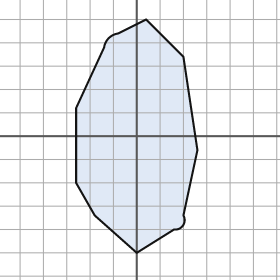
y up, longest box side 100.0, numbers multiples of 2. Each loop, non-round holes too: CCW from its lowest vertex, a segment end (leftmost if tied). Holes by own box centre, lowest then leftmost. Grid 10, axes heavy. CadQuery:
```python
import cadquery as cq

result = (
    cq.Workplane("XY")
    .moveTo(0.0, -50.0)
    .lineTo(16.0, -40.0)
    .threePointArc((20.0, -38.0), (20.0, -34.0))
    .lineTo(26.0, -6.0)
    .lineTo(20.0, 34.0)
    .lineTo(4.0, 50.0)
    .lineTo(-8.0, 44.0)
    .threePointArc((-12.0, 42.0), (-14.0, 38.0))
    .lineTo(-26.0, 12.0)
    .lineTo(-26.0, -20.0)
    .lineTo(-18.0, -34.0)
    .close()
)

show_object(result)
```